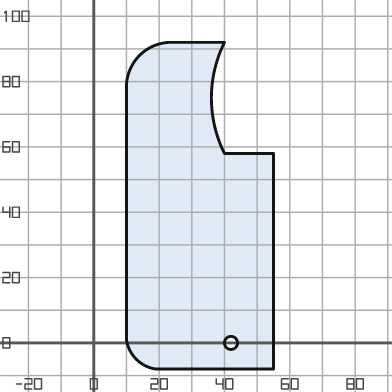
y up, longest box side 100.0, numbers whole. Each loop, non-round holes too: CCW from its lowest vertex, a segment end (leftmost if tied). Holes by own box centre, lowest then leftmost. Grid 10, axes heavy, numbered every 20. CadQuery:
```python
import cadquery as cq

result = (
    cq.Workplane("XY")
    .moveTo(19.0, -8.0)
    .lineTo(55.0, -8.0)
    .lineTo(55.0, 58.0)
    .lineTo(40.0, 58.0)
    .threePointArc((36.0, 75.0), (40.0, 92.0))
    .lineTo(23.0, 92.0)
    .threePointArc((14.0, 88.0), (10.0, 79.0))
    .lineTo(10.0, 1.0)
    .threePointArc((13.0, -5.0), (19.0, -8.0))
    .close()
    .moveTo(42.0, 0.0)
    .circle(2.0)
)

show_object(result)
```